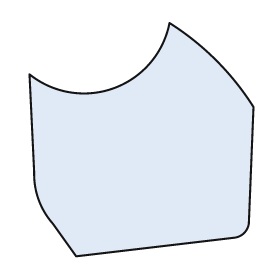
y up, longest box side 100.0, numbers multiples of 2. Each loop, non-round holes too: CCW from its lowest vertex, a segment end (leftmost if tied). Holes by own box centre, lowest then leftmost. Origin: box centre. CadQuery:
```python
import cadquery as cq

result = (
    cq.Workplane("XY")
    .moveTo(-28.0, -50.0)
    .lineTo(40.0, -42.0)
    .threePointArc((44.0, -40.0), (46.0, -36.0))
    .lineTo(48.0, 14.0)
    .threePointArc((32.0, 34.0), (12.0, 50.0))
    .threePointArc((-12.0, 22.0), (-48.0, 28.0))
    .lineTo(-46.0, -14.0)
    .threePointArc((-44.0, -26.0), (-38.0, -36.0))
    .close()
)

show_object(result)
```